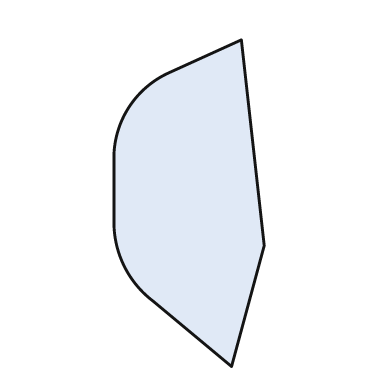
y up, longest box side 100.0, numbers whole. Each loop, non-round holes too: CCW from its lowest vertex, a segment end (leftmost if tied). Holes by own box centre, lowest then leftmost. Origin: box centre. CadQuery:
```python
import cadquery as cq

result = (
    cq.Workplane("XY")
    .moveTo(13.0, -50.0)
    .lineTo(23.0, -13.0)
    .lineTo(16.0, 50.0)
    .lineTo(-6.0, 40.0)
    .threePointArc((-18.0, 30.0), (-23.0, 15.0))
    .lineTo(-23.0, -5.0)
    .threePointArc((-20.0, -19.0), (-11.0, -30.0))
    .close()
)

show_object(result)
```